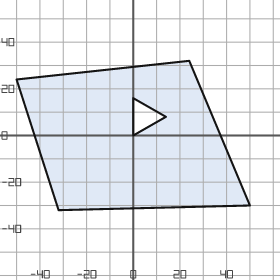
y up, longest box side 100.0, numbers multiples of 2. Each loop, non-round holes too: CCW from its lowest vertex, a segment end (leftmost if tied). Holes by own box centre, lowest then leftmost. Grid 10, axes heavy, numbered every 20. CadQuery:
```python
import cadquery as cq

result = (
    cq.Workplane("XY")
    .moveTo(-32.0, -32.0)
    .lineTo(50.0, -30.0)
    .lineTo(24.0, 32.0)
    .lineTo(-50.0, 24.0)
    .close()
    .moveTo(0.0, 0.0)
    .lineTo(14.0, 8.0)
    .lineTo(0.0, 16.0)
    .close()
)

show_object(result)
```